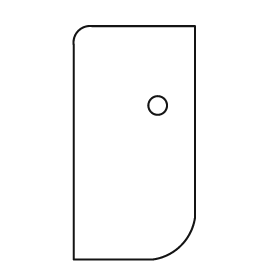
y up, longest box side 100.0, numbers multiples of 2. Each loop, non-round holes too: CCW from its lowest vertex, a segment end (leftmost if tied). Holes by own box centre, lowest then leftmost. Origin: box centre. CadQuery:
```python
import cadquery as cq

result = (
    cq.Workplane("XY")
    .moveTo(-26.0, -50.0)
    .lineTo(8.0, -50.0)
    .threePointArc((20.0, -44.0), (26.0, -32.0))
    .lineTo(26.0, 50.0)
    .lineTo(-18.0, 50.0)
    .threePointArc((-24.0, 48.0), (-26.0, 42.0))
    .close()
    .moveTo(10.0, 16.0)
    .circle(4.0)
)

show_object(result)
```